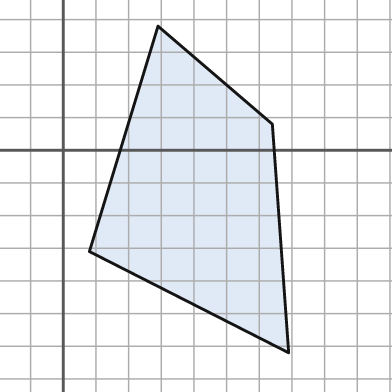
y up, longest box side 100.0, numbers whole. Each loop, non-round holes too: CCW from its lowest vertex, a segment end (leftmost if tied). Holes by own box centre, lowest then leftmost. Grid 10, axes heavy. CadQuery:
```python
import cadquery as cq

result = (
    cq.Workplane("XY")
    .moveTo(69.0, -62.0)
    .lineTo(64.0, 8.0)
    .lineTo(29.0, 38.0)
    .lineTo(8.0, -31.0)
    .close()
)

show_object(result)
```